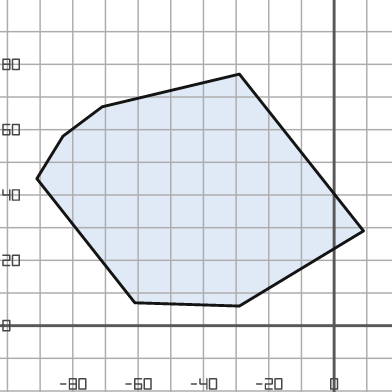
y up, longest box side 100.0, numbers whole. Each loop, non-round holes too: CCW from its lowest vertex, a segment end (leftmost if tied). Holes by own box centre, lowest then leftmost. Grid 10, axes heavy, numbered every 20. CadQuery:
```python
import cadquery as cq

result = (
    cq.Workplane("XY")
    .moveTo(-29.0, 6.0)
    .lineTo(9.0, 29.0)
    .lineTo(-29.0, 77.0)
    .lineTo(-71.0, 67.0)
    .lineTo(-83.0, 58.0)
    .lineTo(-91.0, 45.0)
    .lineTo(-61.0, 7.0)
    .close()
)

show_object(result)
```